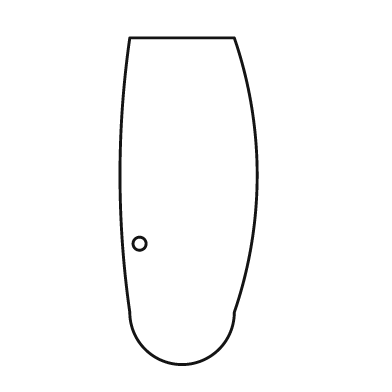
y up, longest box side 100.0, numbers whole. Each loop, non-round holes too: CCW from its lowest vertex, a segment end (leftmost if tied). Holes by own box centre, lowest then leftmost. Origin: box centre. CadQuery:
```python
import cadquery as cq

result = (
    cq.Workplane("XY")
    .moveTo(-18.0, -34.0)
    .threePointArc((-2.0, -50.0), (14.0, -34.0))
    .threePointArc((21.0, 8.0), (14.0, 50.0))
    .lineTo(-18.0, 50.0)
    .threePointArc((-21.0, 8.0), (-18.0, -34.0))
    .close()
    .moveTo(-15.0, -13.0)
    .circle(2.0)
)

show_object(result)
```